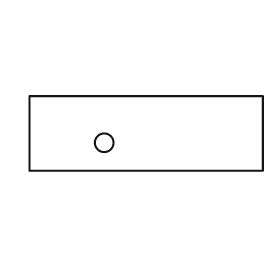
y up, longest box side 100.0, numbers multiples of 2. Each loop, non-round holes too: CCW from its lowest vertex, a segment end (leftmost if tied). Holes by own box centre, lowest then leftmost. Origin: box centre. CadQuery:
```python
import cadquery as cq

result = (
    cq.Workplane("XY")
    .moveTo(-50.0, -16.0)
    .lineTo(50.0, -16.0)
    .lineTo(50.0, 16.0)
    .lineTo(-50.0, 16.0)
    .close()
    .moveTo(-18.0, -4.0)
    .circle(4.0)
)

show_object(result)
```